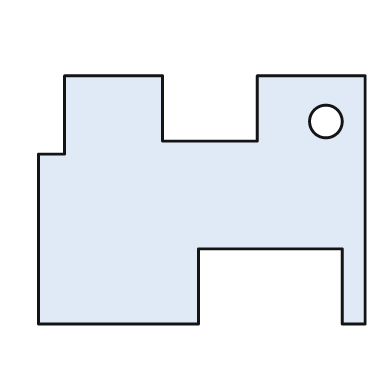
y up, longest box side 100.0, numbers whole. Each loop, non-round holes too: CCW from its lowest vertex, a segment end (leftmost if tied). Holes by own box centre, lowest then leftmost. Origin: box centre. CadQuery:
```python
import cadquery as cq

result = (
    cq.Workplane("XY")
    .moveTo(-50.0, -38.0)
    .lineTo(-1.0, -38.0)
    .lineTo(-1.0, -15.0)
    .lineTo(43.0, -15.0)
    .lineTo(43.0, -38.0)
    .lineTo(50.0, -38.0)
    .lineTo(50.0, 38.0)
    .lineTo(17.0, 38.0)
    .lineTo(17.0, 18.0)
    .lineTo(-12.0, 18.0)
    .lineTo(-12.0, 38.0)
    .lineTo(-42.0, 38.0)
    .lineTo(-42.0, 14.0)
    .lineTo(-50.0, 14.0)
    .close()
    .moveTo(38.0, 24.0)
    .circle(5.0)
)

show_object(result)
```